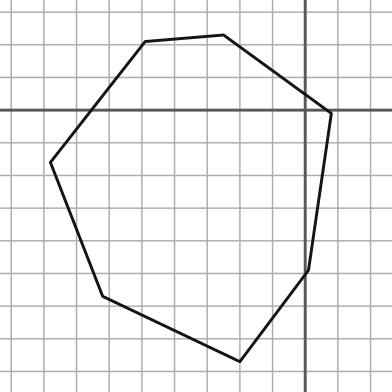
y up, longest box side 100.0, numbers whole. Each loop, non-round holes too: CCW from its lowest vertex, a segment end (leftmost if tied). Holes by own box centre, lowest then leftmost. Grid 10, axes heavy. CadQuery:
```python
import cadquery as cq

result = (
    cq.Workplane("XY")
    .moveTo(-20.0, -77.0)
    .lineTo(1.0, -49.0)
    .lineTo(8.0, -1.0)
    .lineTo(-25.0, 23.0)
    .lineTo(-49.0, 21.0)
    .lineTo(-78.0, -16.0)
    .lineTo(-62.0, -57.0)
    .close()
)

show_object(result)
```